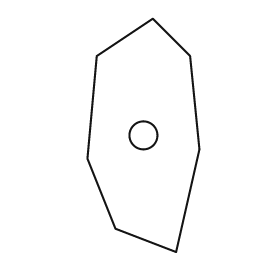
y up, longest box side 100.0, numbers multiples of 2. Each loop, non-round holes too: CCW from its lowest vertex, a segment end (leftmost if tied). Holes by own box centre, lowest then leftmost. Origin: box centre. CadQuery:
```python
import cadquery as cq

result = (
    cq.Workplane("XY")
    .moveTo(14.0, -50.0)
    .lineTo(24.0, -6.0)
    .lineTo(20.0, 34.0)
    .lineTo(4.0, 50.0)
    .lineTo(-20.0, 34.0)
    .lineTo(-24.0, -10.0)
    .lineTo(-12.0, -40.0)
    .close()
    .moveTo(0.0, 0.0)
    .circle(6.0)
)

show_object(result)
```